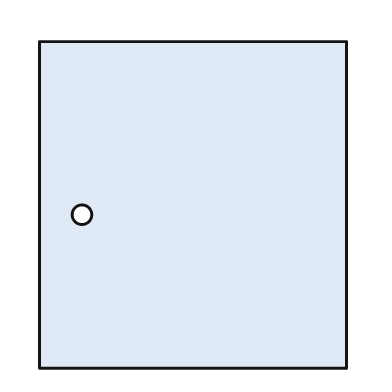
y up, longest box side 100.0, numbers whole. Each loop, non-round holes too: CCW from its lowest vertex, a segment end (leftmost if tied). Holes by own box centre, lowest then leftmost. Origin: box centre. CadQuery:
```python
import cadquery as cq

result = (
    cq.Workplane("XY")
    .moveTo(-47.0, -50.0)
    .lineTo(47.0, -50.0)
    .lineTo(47.0, 50.0)
    .lineTo(-47.0, 50.0)
    .close()
    .moveTo(-34.0, -3.0)
    .circle(3.0)
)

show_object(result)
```